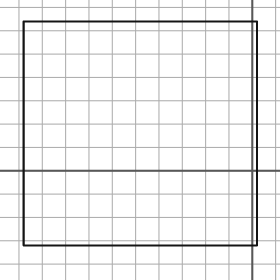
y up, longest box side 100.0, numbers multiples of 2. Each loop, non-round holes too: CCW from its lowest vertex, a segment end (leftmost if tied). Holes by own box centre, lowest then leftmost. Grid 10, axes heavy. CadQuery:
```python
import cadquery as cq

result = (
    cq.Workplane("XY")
    .moveTo(-98.0, -32.0)
    .lineTo(2.0, -32.0)
    .lineTo(2.0, 64.0)
    .lineTo(-98.0, 64.0)
    .close()
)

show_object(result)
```